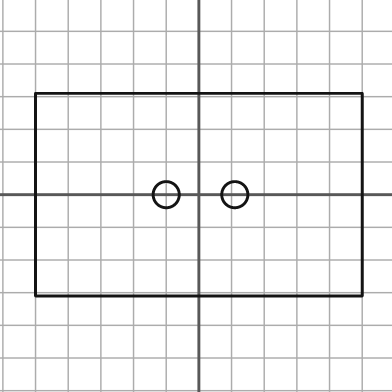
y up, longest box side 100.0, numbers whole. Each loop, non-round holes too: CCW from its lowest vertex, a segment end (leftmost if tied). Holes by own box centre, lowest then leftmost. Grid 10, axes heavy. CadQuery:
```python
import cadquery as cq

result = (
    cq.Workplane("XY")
    .moveTo(-50.0, -31.0)
    .lineTo(50.0, -31.0)
    .lineTo(50.0, 31.0)
    .lineTo(-50.0, 31.0)
    .close()
    .moveTo(-10.0, 0.0)
    .circle(4.0)
    .moveTo(11.0, 0.0)
    .circle(4.0)
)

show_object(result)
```